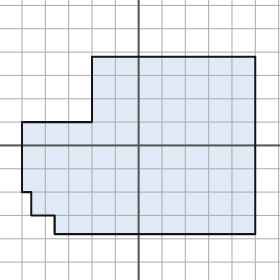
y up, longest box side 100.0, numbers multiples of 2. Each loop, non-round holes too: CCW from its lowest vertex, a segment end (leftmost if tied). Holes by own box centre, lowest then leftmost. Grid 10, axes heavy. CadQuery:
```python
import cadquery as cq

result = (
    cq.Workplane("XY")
    .moveTo(-36.0, -38.0)
    .lineTo(50.0, -38.0)
    .lineTo(50.0, 38.0)
    .lineTo(-20.0, 38.0)
    .lineTo(-20.0, 10.0)
    .lineTo(-50.0, 10.0)
    .lineTo(-50.0, -20.0)
    .lineTo(-46.0, -20.0)
    .lineTo(-46.0, -30.0)
    .lineTo(-36.0, -30.0)
    .close()
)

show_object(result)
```